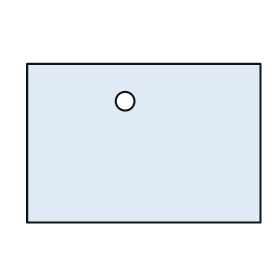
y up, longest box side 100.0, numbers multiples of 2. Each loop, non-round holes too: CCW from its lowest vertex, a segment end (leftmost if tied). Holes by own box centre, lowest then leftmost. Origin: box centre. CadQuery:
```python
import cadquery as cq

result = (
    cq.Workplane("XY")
    .moveTo(-50.0, -34.0)
    .lineTo(50.0, -34.0)
    .lineTo(50.0, 34.0)
    .lineTo(-50.0, 34.0)
    .close()
    .moveTo(-8.0, 18.0)
    .circle(4.0)
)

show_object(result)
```